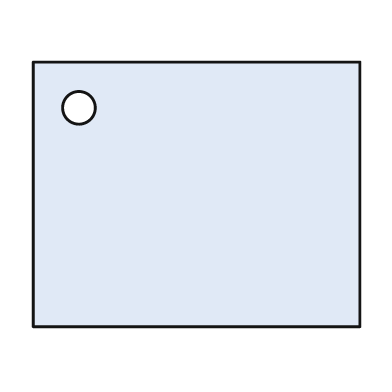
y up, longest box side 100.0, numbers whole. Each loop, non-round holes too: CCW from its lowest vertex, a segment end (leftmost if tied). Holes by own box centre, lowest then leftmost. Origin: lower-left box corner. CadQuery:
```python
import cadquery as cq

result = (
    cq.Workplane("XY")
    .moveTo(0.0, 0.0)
    .lineTo(100.0, 0.0)
    .lineTo(100.0, 81.0)
    .lineTo(0.0, 81.0)
    .close()
    .moveTo(14.0, 67.0)
    .circle(5.0)
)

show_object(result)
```